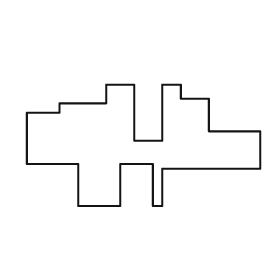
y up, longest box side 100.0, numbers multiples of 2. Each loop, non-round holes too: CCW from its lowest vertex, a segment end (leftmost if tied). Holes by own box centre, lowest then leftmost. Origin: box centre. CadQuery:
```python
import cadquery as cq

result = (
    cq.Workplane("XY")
    .moveTo(-28.0, -26.0)
    .lineTo(-10.0, -26.0)
    .lineTo(-10.0, -8.0)
    .lineTo(4.0, -8.0)
    .lineTo(4.0, -26.0)
    .lineTo(8.0, -26.0)
    .lineTo(8.0, -10.0)
    .lineTo(50.0, -10.0)
    .lineTo(50.0, 6.0)
    .lineTo(28.0, 6.0)
    .lineTo(28.0, 20.0)
    .lineTo(16.0, 20.0)
    .lineTo(16.0, 26.0)
    .lineTo(8.0, 26.0)
    .lineTo(8.0, 2.0)
    .lineTo(-4.0, 2.0)
    .lineTo(-4.0, 26.0)
    .lineTo(-16.0, 26.0)
    .lineTo(-16.0, 18.0)
    .lineTo(-36.0, 18.0)
    .lineTo(-36.0, 14.0)
    .lineTo(-50.0, 14.0)
    .lineTo(-50.0, -8.0)
    .lineTo(-28.0, -8.0)
    .close()
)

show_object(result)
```